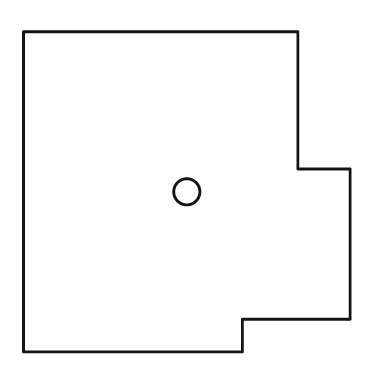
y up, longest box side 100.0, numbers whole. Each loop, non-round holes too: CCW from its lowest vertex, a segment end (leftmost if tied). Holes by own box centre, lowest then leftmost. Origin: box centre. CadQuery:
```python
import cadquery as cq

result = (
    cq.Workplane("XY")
    .moveTo(-50.0, -49.0)
    .lineTo(17.0, -49.0)
    .lineTo(17.0, -39.0)
    .lineTo(50.0, -39.0)
    .lineTo(50.0, 7.0)
    .lineTo(34.0, 7.0)
    .lineTo(34.0, 49.0)
    .lineTo(-50.0, 49.0)
    .close()
    .moveTo(0.0, 0.0)
    .circle(4.0)
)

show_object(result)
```